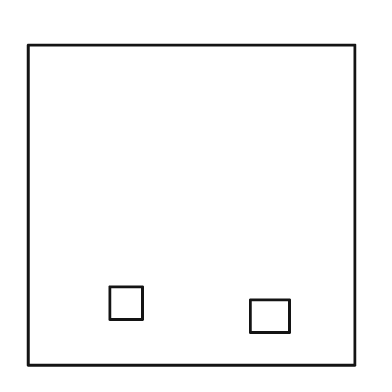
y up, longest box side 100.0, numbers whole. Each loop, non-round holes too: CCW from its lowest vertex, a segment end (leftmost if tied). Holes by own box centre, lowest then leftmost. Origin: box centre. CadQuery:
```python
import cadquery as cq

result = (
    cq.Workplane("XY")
    .moveTo(-50.0, -49.0)
    .lineTo(50.0, -49.0)
    .lineTo(50.0, 49.0)
    .lineTo(-50.0, 49.0)
    .close()
    .moveTo(18.0, -39.0)
    .lineTo(30.0, -39.0)
    .lineTo(30.0, -29.0)
    .lineTo(18.0, -29.0)
    .close()
    .moveTo(-25.0, -35.0)
    .lineTo(-15.0, -35.0)
    .lineTo(-15.0, -25.0)
    .lineTo(-25.0, -25.0)
    .close()
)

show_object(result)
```